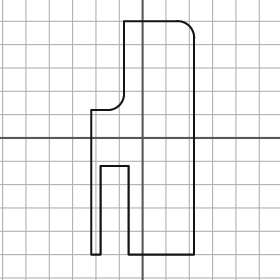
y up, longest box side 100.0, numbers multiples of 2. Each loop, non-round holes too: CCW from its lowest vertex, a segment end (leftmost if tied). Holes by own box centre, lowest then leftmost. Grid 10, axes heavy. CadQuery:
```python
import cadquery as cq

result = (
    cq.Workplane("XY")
    .moveTo(-22.0, -50.0)
    .lineTo(-18.0, -50.0)
    .lineTo(-18.0, -12.0)
    .lineTo(-6.0, -12.0)
    .lineTo(-6.0, -50.0)
    .lineTo(22.0, -50.0)
    .lineTo(22.0, 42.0)
    .threePointArc((20.0, 48.0), (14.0, 50.0))
    .lineTo(-8.0, 50.0)
    .lineTo(-8.0, 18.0)
    .threePointArc((-10.0, 14.0), (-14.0, 12.0))
    .lineTo(-22.0, 12.0)
    .close()
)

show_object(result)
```